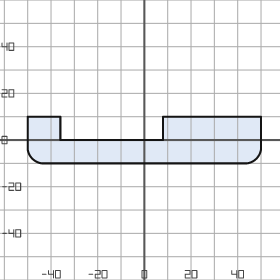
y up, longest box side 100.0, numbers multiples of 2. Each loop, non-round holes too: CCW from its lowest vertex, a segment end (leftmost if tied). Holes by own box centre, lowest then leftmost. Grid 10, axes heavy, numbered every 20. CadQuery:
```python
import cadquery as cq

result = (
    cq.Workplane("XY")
    .moveTo(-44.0, -10.0)
    .lineTo(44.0, -10.0)
    .threePointArc((48.0, -8.0), (50.0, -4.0))
    .lineTo(50.0, 10.0)
    .lineTo(8.0, 10.0)
    .lineTo(8.0, 0.0)
    .lineTo(-36.0, 0.0)
    .lineTo(-36.0, 10.0)
    .lineTo(-50.0, 10.0)
    .lineTo(-50.0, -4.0)
    .threePointArc((-48.0, -8.0), (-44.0, -10.0))
    .close()
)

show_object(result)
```